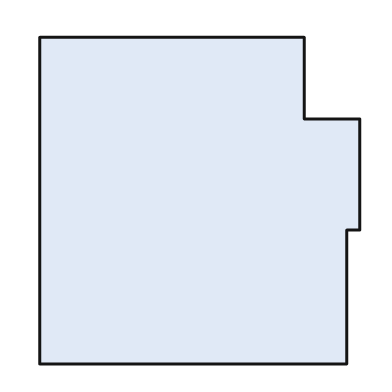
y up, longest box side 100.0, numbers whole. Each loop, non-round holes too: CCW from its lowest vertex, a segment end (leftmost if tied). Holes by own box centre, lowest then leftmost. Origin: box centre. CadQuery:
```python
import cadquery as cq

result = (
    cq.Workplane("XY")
    .moveTo(-49.0, -50.0)
    .lineTo(45.0, -50.0)
    .lineTo(45.0, -9.0)
    .lineTo(49.0, -9.0)
    .lineTo(49.0, 25.0)
    .lineTo(32.0, 25.0)
    .lineTo(32.0, 50.0)
    .lineTo(-49.0, 50.0)
    .close()
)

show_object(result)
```